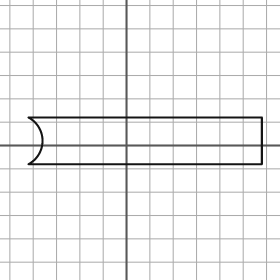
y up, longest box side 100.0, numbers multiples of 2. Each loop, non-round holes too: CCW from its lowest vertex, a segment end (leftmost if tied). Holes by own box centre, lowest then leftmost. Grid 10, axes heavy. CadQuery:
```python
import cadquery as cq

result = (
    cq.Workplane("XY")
    .moveTo(-42.0, -8.0)
    .lineTo(58.0, -8.0)
    .lineTo(58.0, 12.0)
    .lineTo(-42.0, 12.0)
    .threePointArc((-36.0, 2.0), (-42.0, -8.0))
    .close()
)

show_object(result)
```